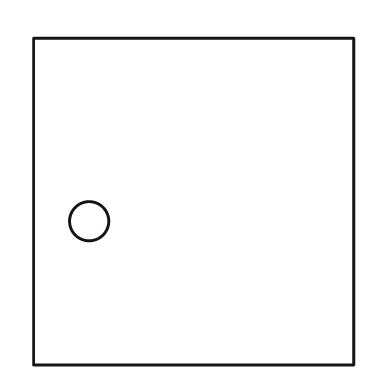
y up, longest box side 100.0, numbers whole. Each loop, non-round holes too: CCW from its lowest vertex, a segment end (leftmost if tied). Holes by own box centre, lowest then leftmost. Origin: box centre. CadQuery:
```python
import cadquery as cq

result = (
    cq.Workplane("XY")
    .moveTo(-49.0, -50.0)
    .lineTo(49.0, -50.0)
    .lineTo(49.0, 50.0)
    .lineTo(-49.0, 50.0)
    .close()
    .moveTo(-32.0, -6.0)
    .circle(6.0)
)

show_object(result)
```